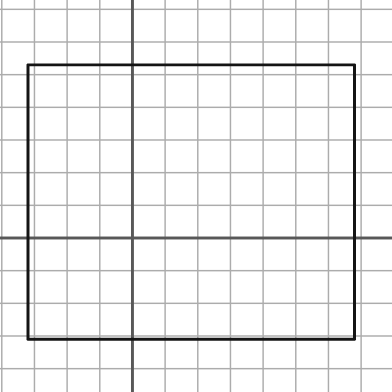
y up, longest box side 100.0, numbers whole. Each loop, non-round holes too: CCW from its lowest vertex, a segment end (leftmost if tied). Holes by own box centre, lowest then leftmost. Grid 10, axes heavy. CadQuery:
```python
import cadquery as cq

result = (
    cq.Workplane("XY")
    .moveTo(-32.0, -31.0)
    .lineTo(68.0, -31.0)
    .lineTo(68.0, 53.0)
    .lineTo(-32.0, 53.0)
    .close()
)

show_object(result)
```